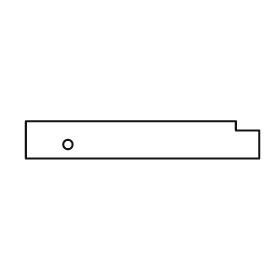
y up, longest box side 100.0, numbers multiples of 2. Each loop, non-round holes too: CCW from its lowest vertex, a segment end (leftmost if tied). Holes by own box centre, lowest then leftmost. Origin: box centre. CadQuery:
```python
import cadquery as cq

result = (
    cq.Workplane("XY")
    .moveTo(-50.0, -8.0)
    .lineTo(50.0, -8.0)
    .lineTo(50.0, 4.0)
    .lineTo(40.0, 4.0)
    .lineTo(40.0, 8.0)
    .lineTo(-50.0, 8.0)
    .close()
    .moveTo(-32.0, -2.0)
    .circle(2.0)
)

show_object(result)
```